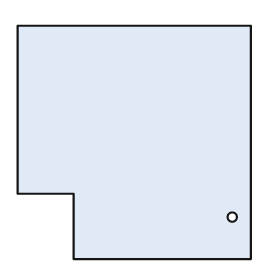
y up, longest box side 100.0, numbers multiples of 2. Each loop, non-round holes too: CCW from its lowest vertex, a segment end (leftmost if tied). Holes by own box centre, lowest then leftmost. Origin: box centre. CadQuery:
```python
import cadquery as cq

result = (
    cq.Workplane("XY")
    .moveTo(-26.0, -50.0)
    .lineTo(50.0, -50.0)
    .lineTo(50.0, 50.0)
    .lineTo(-50.0, 50.0)
    .lineTo(-50.0, -22.0)
    .lineTo(-26.0, -22.0)
    .close()
    .moveTo(42.0, -32.0)
    .circle(2.0)
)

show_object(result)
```